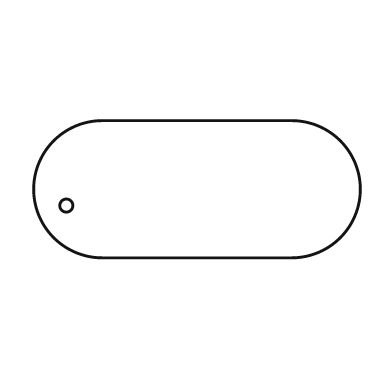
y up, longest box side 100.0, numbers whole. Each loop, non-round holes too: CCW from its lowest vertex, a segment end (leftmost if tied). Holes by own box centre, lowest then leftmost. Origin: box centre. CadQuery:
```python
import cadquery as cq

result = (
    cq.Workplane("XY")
    .moveTo(-29.0, -21.0)
    .lineTo(29.0, -21.0)
    .threePointArc((50.0, 0.0), (29.0, 21.0))
    .lineTo(-29.0, 21.0)
    .threePointArc((-50.0, 0.0), (-29.0, -21.0))
    .close()
    .moveTo(-40.0, -5.0)
    .circle(2.0)
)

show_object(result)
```